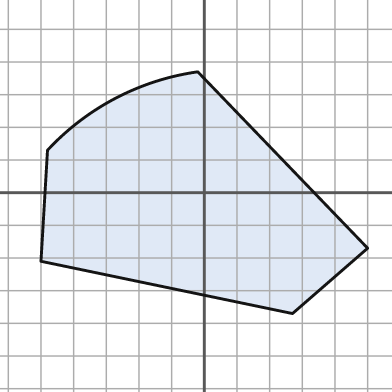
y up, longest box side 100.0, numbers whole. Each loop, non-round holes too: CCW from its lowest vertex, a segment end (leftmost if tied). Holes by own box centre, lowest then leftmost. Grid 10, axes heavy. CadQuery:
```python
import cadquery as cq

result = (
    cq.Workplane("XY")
    .moveTo(27.0, -37.0)
    .lineTo(50.0, -17.0)
    .lineTo(-2.0, 37.0)
    .threePointArc((-27.0, 29.0), (-48.0, 13.0))
    .lineTo(-50.0, -21.0)
    .close()
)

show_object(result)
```